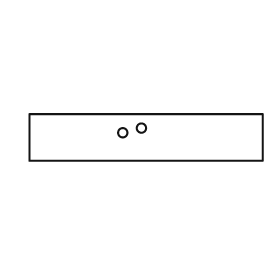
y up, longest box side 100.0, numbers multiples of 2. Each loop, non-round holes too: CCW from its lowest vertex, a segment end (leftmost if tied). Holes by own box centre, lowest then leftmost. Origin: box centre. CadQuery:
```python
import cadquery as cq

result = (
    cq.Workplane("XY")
    .moveTo(-50.0, -10.0)
    .lineTo(50.0, -10.0)
    .lineTo(50.0, 10.0)
    .lineTo(-50.0, 10.0)
    .close()
    .moveTo(-10.0, 2.0)
    .circle(2.0)
    .moveTo(-2.0, 4.0)
    .circle(2.0)
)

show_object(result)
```